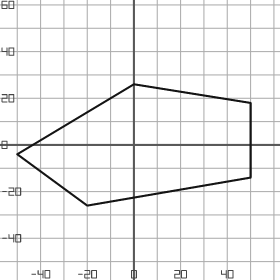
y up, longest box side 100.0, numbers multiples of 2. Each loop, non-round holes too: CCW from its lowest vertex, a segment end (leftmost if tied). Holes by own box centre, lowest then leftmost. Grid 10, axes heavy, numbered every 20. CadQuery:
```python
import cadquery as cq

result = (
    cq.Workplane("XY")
    .moveTo(-20.0, -26.0)
    .lineTo(50.0, -14.0)
    .lineTo(50.0, 18.0)
    .lineTo(0.0, 26.0)
    .lineTo(-50.0, -4.0)
    .close()
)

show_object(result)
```